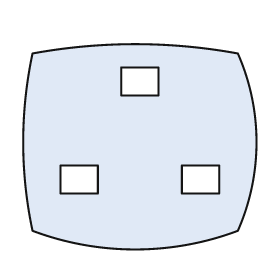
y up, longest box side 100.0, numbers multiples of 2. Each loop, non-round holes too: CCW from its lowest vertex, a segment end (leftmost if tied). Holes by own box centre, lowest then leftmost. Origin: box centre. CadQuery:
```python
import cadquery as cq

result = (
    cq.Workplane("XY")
    .moveTo(-46.0, -36.0)
    .threePointArc((-2.0, -44.0), (42.0, -36.0))
    .threePointArc((50.0, 2.0), (42.0, 40.0))
    .threePointArc((-2.0, 44.0), (-46.0, 40.0))
    .threePointArc((-50.0, 2.0), (-46.0, -36.0))
    .close()
    .moveTo(-34.0, -20.0)
    .lineTo(-18.0, -20.0)
    .lineTo(-18.0, -8.0)
    .lineTo(-34.0, -8.0)
    .close()
    .moveTo(18.0, -20.0)
    .lineTo(34.0, -20.0)
    .lineTo(34.0, -8.0)
    .lineTo(18.0, -8.0)
    .close()
    .moveTo(-8.0, 22.0)
    .lineTo(8.0, 22.0)
    .lineTo(8.0, 34.0)
    .lineTo(-8.0, 34.0)
    .close()
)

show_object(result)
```